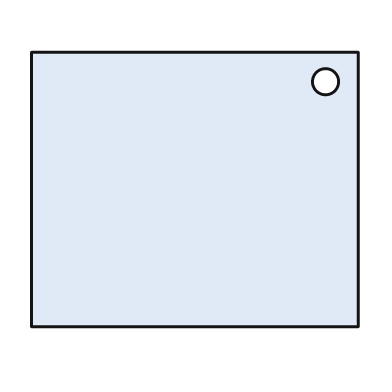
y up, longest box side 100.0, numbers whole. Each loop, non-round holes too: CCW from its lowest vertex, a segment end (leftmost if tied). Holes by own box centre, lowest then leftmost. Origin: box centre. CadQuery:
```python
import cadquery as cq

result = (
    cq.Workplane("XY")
    .moveTo(-50.0, -42.0)
    .lineTo(50.0, -42.0)
    .lineTo(50.0, 42.0)
    .lineTo(-50.0, 42.0)
    .close()
    .moveTo(40.0, 33.0)
    .circle(4.0)
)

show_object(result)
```